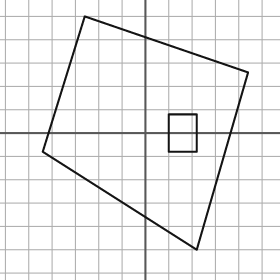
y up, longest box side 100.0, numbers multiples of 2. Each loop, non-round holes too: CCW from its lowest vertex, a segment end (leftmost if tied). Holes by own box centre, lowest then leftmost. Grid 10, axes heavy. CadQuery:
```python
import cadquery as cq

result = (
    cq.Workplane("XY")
    .moveTo(22.0, -50.0)
    .lineTo(44.0, 26.0)
    .lineTo(-26.0, 50.0)
    .lineTo(-44.0, -8.0)
    .close()
    .moveTo(10.0, -8.0)
    .lineTo(22.0, -8.0)
    .lineTo(22.0, 8.0)
    .lineTo(10.0, 8.0)
    .close()
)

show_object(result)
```